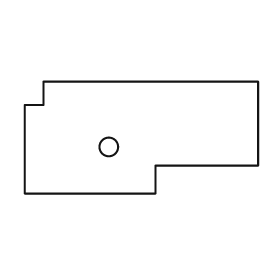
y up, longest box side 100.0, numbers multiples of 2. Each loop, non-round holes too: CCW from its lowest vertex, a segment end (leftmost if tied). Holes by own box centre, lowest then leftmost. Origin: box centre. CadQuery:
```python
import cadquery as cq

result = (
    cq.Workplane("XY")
    .moveTo(-50.0, -24.0)
    .lineTo(6.0, -24.0)
    .lineTo(6.0, -12.0)
    .lineTo(50.0, -12.0)
    .lineTo(50.0, 24.0)
    .lineTo(-42.0, 24.0)
    .lineTo(-42.0, 14.0)
    .lineTo(-50.0, 14.0)
    .close()
    .moveTo(-14.0, -4.0)
    .circle(4.0)
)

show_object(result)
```